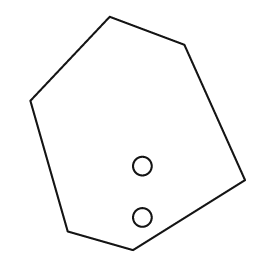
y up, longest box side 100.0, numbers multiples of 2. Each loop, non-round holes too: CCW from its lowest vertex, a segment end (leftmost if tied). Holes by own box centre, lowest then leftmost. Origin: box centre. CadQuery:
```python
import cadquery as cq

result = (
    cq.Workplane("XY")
    .moveTo(-2.0, -50.0)
    .lineTo(46.0, -20.0)
    .lineTo(20.0, 38.0)
    .lineTo(-12.0, 50.0)
    .lineTo(-46.0, 14.0)
    .lineTo(-30.0, -42.0)
    .close()
    .moveTo(2.0, -36.0)
    .circle(4.0)
    .moveTo(2.0, -14.0)
    .circle(4.0)
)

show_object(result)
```